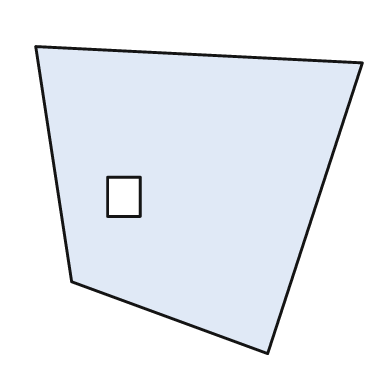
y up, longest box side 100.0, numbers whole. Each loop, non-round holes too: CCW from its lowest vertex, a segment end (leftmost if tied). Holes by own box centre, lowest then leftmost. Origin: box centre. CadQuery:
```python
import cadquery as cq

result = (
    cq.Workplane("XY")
    .moveTo(21.0, -47.0)
    .lineTo(50.0, 42.0)
    .lineTo(-50.0, 47.0)
    .lineTo(-39.0, -25.0)
    .close()
    .moveTo(-28.0, -5.0)
    .lineTo(-18.0, -5.0)
    .lineTo(-18.0, 7.0)
    .lineTo(-28.0, 7.0)
    .close()
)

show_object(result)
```